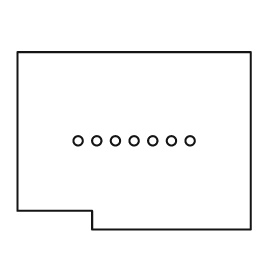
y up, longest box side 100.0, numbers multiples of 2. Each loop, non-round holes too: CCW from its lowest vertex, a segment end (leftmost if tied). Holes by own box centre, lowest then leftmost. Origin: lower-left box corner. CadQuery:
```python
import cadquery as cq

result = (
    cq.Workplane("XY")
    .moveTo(32.0, 0.0)
    .lineTo(100.0, 0.0)
    .lineTo(100.0, 76.0)
    .lineTo(0.0, 76.0)
    .lineTo(0.0, 8.0)
    .lineTo(32.0, 8.0)
    .close()
    .moveTo(26.0, 38.0)
    .circle(2.0)
    .moveTo(34.0, 38.0)
    .circle(2.0)
    .moveTo(42.0, 38.0)
    .circle(2.0)
    .moveTo(50.0, 38.0)
    .circle(2.0)
    .moveTo(58.0, 38.0)
    .circle(2.0)
    .moveTo(66.0, 38.0)
    .circle(2.0)
    .moveTo(74.0, 38.0)
    .circle(2.0)
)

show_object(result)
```